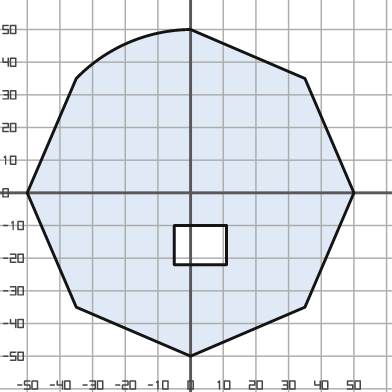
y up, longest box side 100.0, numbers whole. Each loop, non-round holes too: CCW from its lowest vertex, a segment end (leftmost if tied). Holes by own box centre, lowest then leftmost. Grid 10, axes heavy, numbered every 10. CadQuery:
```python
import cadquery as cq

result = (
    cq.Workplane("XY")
    .moveTo(0.0, -50.0)
    .lineTo(35.0, -35.0)
    .lineTo(50.0, 0.0)
    .lineTo(35.0, 35.0)
    .lineTo(0.0, 50.0)
    .threePointArc((-19.0, 46.0), (-35.0, 35.0))
    .lineTo(-50.0, 0.0)
    .lineTo(-35.0, -35.0)
    .close()
    .moveTo(-5.0, -22.0)
    .lineTo(11.0, -22.0)
    .lineTo(11.0, -10.0)
    .lineTo(-5.0, -10.0)
    .close()
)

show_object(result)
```